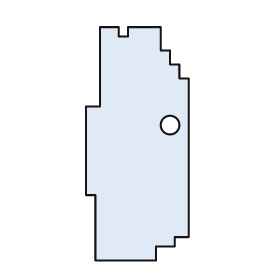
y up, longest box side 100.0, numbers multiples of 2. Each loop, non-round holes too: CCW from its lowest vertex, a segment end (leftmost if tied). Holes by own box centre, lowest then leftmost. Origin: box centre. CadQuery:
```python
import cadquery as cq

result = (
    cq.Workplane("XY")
    .moveTo(-18.0, -50.0)
    .lineTo(8.0, -50.0)
    .lineTo(8.0, -44.0)
    .lineTo(16.0, -44.0)
    .lineTo(16.0, -40.0)
    .lineTo(22.0, -40.0)
    .lineTo(22.0, 28.0)
    .lineTo(18.0, 28.0)
    .lineTo(18.0, 34.0)
    .lineTo(14.0, 34.0)
    .lineTo(14.0, 40.0)
    .lineTo(10.0, 40.0)
    .lineTo(10.0, 50.0)
    .lineTo(-4.0, 50.0)
    .lineTo(-4.0, 46.0)
    .lineTo(-8.0, 46.0)
    .lineTo(-8.0, 50.0)
    .lineTo(-16.0, 50.0)
    .lineTo(-16.0, 16.0)
    .lineTo(-22.0, 16.0)
    .lineTo(-22.0, -22.0)
    .lineTo(-18.0, -22.0)
    .close()
    .moveTo(14.0, 8.0)
    .circle(4.0)
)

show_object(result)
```